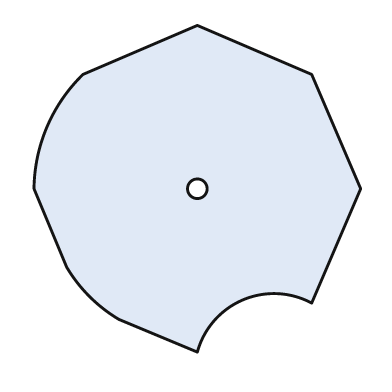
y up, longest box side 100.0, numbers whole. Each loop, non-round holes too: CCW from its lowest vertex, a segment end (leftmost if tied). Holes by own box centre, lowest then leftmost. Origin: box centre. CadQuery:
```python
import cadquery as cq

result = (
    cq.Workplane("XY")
    .moveTo(0.0, -50.0)
    .threePointArc((14.0, -34.0), (35.0, -35.0))
    .lineTo(50.0, 0.0)
    .lineTo(35.0, 35.0)
    .lineTo(0.0, 50.0)
    .lineTo(-35.0, 35.0)
    .threePointArc((-46.0, 19.0), (-50.0, 0.0))
    .lineTo(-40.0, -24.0)
    .threePointArc((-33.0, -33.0), (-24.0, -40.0))
    .close()
    .moveTo(0.0, 0.0)
    .circle(3.0)
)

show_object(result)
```